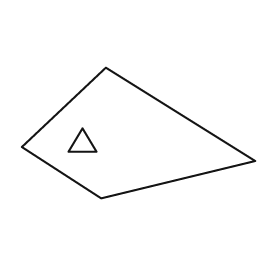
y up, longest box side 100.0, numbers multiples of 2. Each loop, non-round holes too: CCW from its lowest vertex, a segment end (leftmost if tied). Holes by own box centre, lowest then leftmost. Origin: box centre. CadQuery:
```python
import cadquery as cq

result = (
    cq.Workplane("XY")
    .moveTo(-16.0, -28.0)
    .lineTo(50.0, -12.0)
    .lineTo(-14.0, 28.0)
    .lineTo(-50.0, -6.0)
    .close()
    .moveTo(-30.0, -8.0)
    .lineTo(-18.0, -8.0)
    .lineTo(-24.0, 2.0)
    .close()
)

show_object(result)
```